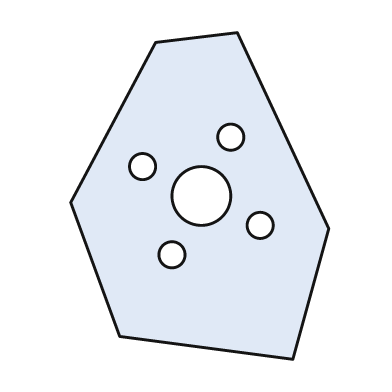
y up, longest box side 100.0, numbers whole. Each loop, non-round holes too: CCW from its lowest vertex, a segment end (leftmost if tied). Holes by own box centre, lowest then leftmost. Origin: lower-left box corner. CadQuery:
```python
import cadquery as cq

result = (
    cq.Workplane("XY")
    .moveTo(68.0, 0.0)
    .lineTo(79.0, 40.0)
    .lineTo(51.0, 100.0)
    .lineTo(26.0, 97.0)
    .lineTo(0.0, 48.0)
    .lineTo(15.0, 7.0)
    .close()
    .moveTo(31.0, 32.0)
    .circle(4.0)
    .moveTo(58.0, 41.0)
    .circle(4.0)
    .moveTo(40.0, 50.0)
    .circle(9.0)
    .moveTo(22.0, 59.0)
    .circle(4.0)
    .moveTo(49.0, 68.0)
    .circle(4.0)
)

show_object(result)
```